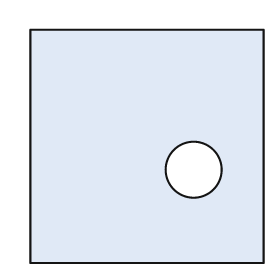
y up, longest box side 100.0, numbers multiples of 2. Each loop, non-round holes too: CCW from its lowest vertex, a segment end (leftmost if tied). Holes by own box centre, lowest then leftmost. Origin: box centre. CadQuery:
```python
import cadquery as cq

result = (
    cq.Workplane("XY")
    .moveTo(-50.0, -50.0)
    .lineTo(50.0, -50.0)
    .lineTo(50.0, 50.0)
    .lineTo(-50.0, 50.0)
    .close()
    .moveTo(20.0, -10.0)
    .circle(12.0)
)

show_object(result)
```